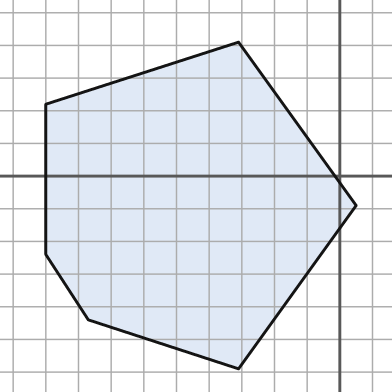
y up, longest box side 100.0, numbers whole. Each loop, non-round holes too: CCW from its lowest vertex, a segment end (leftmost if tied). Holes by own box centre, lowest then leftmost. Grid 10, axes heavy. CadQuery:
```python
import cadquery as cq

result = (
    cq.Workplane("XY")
    .moveTo(-31.0, -59.0)
    .lineTo(5.0, -9.0)
    .lineTo(-31.0, 41.0)
    .lineTo(-90.0, 22.0)
    .lineTo(-90.0, -24.0)
    .lineTo(-77.0, -44.0)
    .close()
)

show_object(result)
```